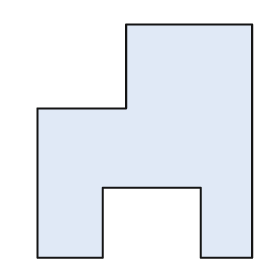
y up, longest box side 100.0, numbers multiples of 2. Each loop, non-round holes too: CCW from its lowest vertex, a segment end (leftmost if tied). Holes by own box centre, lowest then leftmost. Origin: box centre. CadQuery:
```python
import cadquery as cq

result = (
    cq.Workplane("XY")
    .moveTo(-46.0, -50.0)
    .lineTo(-18.0, -50.0)
    .lineTo(-18.0, -20.0)
    .lineTo(24.0, -20.0)
    .lineTo(24.0, -50.0)
    .lineTo(46.0, -50.0)
    .lineTo(46.0, 50.0)
    .lineTo(-8.0, 50.0)
    .lineTo(-8.0, 14.0)
    .lineTo(-46.0, 14.0)
    .close()
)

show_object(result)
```